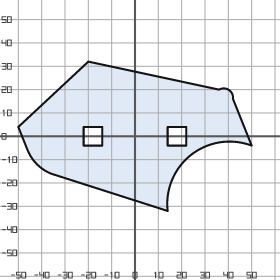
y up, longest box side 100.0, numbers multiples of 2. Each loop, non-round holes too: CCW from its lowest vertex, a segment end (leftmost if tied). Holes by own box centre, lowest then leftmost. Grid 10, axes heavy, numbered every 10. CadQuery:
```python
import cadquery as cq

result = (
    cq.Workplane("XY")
    .moveTo(14.0, -32.0)
    .threePointArc((24.0, -8.0), (50.0, -4.0))
    .lineTo(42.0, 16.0)
    .threePointArc((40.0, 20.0), (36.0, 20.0))
    .lineTo(-20.0, 32.0)
    .lineTo(-50.0, 4.0)
    .lineTo(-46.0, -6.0)
    .threePointArc((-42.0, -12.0), (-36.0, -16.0))
    .close()
    .moveTo(-22.0, -4.0)
    .lineTo(-14.0, -4.0)
    .lineTo(-14.0, 4.0)
    .lineTo(-22.0, 4.0)
    .close()
    .moveTo(14.0, -4.0)
    .lineTo(22.0, -4.0)
    .lineTo(22.0, 4.0)
    .lineTo(14.0, 4.0)
    .close()
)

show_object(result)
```